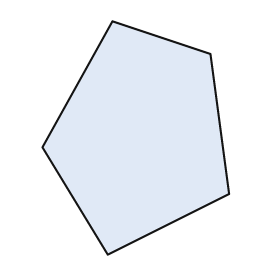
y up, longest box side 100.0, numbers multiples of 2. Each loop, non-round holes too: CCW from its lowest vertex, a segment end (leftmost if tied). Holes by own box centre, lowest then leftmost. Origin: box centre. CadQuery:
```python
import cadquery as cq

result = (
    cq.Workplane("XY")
    .moveTo(-12.0, -50.0)
    .lineTo(40.0, -24.0)
    .lineTo(32.0, 36.0)
    .lineTo(-10.0, 50.0)
    .lineTo(-40.0, -4.0)
    .close()
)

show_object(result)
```